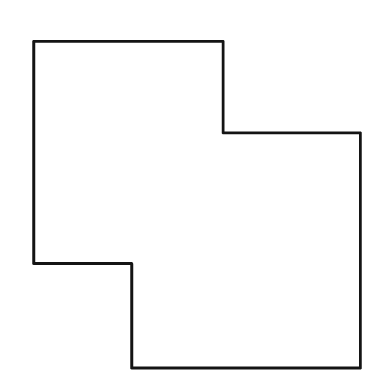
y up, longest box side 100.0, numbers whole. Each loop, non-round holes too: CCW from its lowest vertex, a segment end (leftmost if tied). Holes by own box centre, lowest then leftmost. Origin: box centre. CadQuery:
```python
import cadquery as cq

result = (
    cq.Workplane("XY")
    .moveTo(-20.0, -50.0)
    .lineTo(50.0, -50.0)
    .lineTo(50.0, 22.0)
    .lineTo(8.0, 22.0)
    .lineTo(8.0, 50.0)
    .lineTo(-50.0, 50.0)
    .lineTo(-50.0, -18.0)
    .lineTo(-20.0, -18.0)
    .close()
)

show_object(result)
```